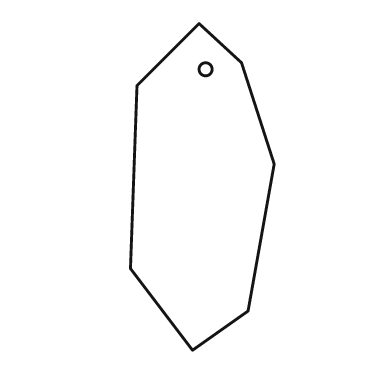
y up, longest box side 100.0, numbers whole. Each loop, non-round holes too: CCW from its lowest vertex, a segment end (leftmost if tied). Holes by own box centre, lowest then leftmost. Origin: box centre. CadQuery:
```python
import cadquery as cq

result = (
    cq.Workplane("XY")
    .moveTo(-3.0, -50.0)
    .lineTo(14.0, -38.0)
    .lineTo(22.0, 7.0)
    .lineTo(12.0, 38.0)
    .lineTo(-1.0, 50.0)
    .lineTo(-20.0, 31.0)
    .lineTo(-22.0, -25.0)
    .close()
    .moveTo(1.0, 36.0)
    .circle(2.0)
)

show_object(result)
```